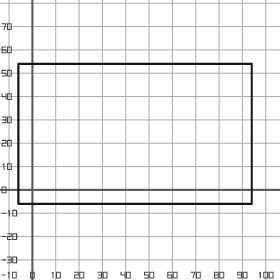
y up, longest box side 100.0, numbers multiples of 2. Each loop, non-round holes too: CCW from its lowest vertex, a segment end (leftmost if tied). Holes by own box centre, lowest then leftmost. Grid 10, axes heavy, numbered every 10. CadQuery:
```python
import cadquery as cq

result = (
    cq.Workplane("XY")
    .moveTo(-6.0, -6.0)
    .lineTo(94.0, -6.0)
    .lineTo(94.0, 54.0)
    .lineTo(-6.0, 54.0)
    .close()
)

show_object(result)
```